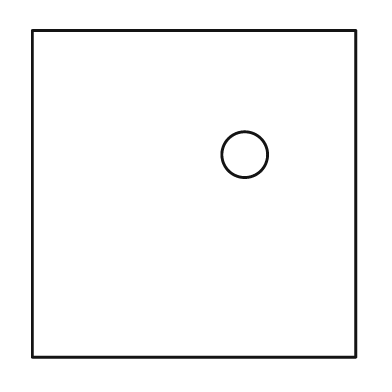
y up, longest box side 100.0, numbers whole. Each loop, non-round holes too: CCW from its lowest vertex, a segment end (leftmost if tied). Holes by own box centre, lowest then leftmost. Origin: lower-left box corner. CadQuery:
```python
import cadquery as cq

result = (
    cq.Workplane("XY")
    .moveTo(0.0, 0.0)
    .lineTo(99.0, 0.0)
    .lineTo(99.0, 100.0)
    .lineTo(0.0, 100.0)
    .close()
    .moveTo(65.0, 62.0)
    .circle(7.0)
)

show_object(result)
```